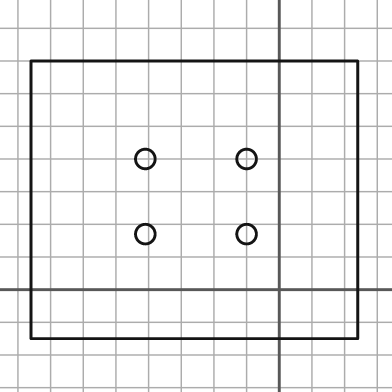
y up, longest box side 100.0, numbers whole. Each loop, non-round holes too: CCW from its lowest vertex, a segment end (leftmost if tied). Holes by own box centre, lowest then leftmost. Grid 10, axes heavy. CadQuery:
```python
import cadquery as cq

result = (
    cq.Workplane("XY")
    .moveTo(-76.0, -15.0)
    .lineTo(24.0, -15.0)
    .lineTo(24.0, 70.0)
    .lineTo(-76.0, 70.0)
    .close()
    .moveTo(-41.0, 17.0)
    .circle(3.0)
    .moveTo(-10.0, 17.0)
    .circle(3.0)
    .moveTo(-41.0, 40.0)
    .circle(3.0)
    .moveTo(-10.0, 40.0)
    .circle(3.0)
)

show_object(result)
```